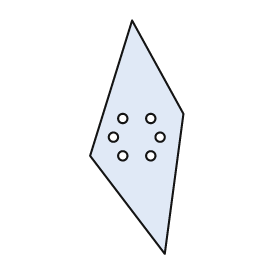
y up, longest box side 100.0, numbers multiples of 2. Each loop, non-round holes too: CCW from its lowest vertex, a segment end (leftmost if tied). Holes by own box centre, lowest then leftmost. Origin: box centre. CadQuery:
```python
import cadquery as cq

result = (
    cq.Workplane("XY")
    .moveTo(12.0, -50.0)
    .lineTo(20.0, 10.0)
    .lineTo(-2.0, 50.0)
    .lineTo(-20.0, -8.0)
    .close()
    .moveTo(-6.0, -8.0)
    .circle(2.0)
    .moveTo(6.0, -8.0)
    .circle(2.0)
    .moveTo(-10.0, 0.0)
    .circle(2.0)
    .moveTo(10.0, 0.0)
    .circle(2.0)
    .moveTo(-6.0, 8.0)
    .circle(2.0)
    .moveTo(6.0, 8.0)
    .circle(2.0)
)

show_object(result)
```